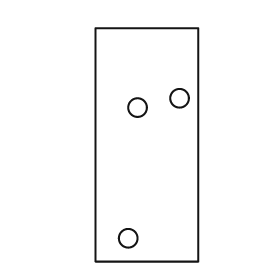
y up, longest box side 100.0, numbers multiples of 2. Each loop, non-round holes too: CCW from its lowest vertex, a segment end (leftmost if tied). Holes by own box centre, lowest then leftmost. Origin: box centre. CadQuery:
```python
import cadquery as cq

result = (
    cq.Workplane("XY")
    .moveTo(-22.0, -50.0)
    .lineTo(22.0, -50.0)
    .lineTo(22.0, 50.0)
    .lineTo(-22.0, 50.0)
    .close()
    .moveTo(-8.0, -40.0)
    .circle(4.0)
    .moveTo(-4.0, 16.0)
    .circle(4.0)
    .moveTo(14.0, 20.0)
    .circle(4.0)
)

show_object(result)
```